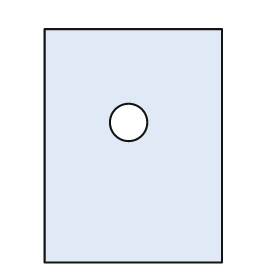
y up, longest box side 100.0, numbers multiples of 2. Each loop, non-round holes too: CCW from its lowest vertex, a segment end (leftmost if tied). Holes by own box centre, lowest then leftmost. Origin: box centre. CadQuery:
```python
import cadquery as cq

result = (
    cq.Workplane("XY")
    .moveTo(-38.0, -50.0)
    .lineTo(38.0, -50.0)
    .lineTo(38.0, 50.0)
    .lineTo(-38.0, 50.0)
    .close()
    .moveTo(-2.0, 10.0)
    .circle(8.0)
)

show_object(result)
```